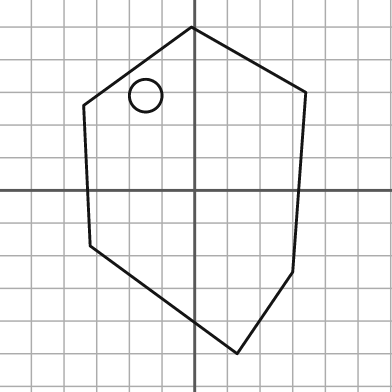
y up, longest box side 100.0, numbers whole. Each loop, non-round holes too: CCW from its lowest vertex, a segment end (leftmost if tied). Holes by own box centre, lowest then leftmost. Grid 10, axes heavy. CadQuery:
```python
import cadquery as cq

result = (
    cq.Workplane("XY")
    .moveTo(13.0, -50.0)
    .lineTo(30.0, -25.0)
    .lineTo(34.0, 30.0)
    .lineTo(-1.0, 50.0)
    .lineTo(-34.0, 26.0)
    .lineTo(-32.0, -17.0)
    .close()
    .moveTo(-15.0, 29.0)
    .circle(5.0)
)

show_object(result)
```